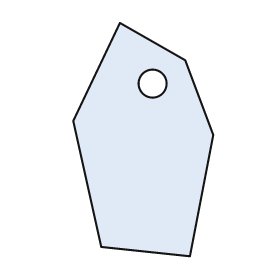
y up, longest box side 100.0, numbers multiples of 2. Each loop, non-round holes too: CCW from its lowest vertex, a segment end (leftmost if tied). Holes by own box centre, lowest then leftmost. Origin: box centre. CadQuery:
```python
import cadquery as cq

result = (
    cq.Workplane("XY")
    .moveTo(20.0, -50.0)
    .lineTo(30.0, 2.0)
    .lineTo(18.0, 34.0)
    .lineTo(-10.0, 50.0)
    .lineTo(-30.0, 8.0)
    .lineTo(-18.0, -46.0)
    .close()
    .moveTo(4.0, 24.0)
    .circle(6.0)
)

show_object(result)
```